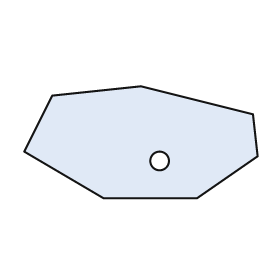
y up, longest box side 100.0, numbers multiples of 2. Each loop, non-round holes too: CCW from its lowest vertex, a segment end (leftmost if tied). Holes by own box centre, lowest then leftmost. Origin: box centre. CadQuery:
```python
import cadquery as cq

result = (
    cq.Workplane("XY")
    .moveTo(-16.0, -24.0)
    .lineTo(24.0, -24.0)
    .lineTo(50.0, -6.0)
    .lineTo(48.0, 12.0)
    .lineTo(0.0, 24.0)
    .lineTo(-38.0, 20.0)
    .lineTo(-50.0, -4.0)
    .close()
    .moveTo(8.0, -8.0)
    .circle(4.0)
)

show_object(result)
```